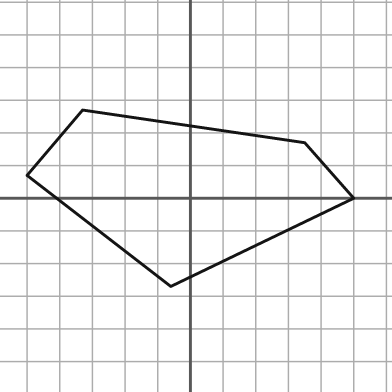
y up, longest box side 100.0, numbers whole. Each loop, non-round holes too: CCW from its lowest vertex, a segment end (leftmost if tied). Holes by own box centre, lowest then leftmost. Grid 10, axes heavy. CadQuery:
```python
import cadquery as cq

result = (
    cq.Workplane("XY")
    .moveTo(-6.0, -27.0)
    .lineTo(50.0, 0.0)
    .lineTo(35.0, 17.0)
    .lineTo(-33.0, 27.0)
    .lineTo(-50.0, 7.0)
    .close()
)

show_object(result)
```